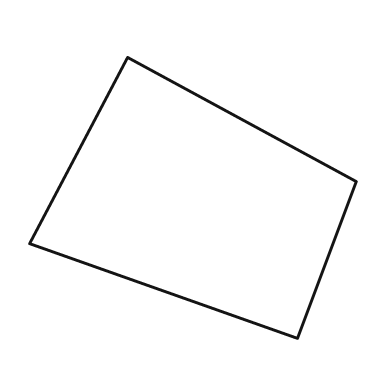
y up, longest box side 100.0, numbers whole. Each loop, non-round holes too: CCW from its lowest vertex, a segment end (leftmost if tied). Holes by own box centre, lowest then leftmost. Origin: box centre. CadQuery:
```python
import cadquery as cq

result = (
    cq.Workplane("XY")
    .moveTo(32.0, -43.0)
    .lineTo(50.0, 5.0)
    .lineTo(-20.0, 43.0)
    .lineTo(-50.0, -14.0)
    .close()
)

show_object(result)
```